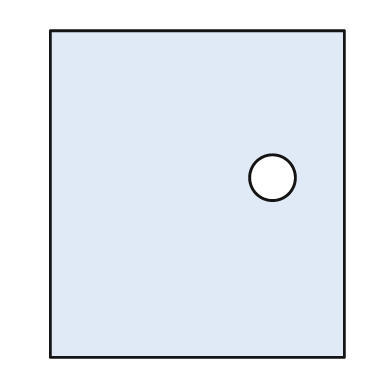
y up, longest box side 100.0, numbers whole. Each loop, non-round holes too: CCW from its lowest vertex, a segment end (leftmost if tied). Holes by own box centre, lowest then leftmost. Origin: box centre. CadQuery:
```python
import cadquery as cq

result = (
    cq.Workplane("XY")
    .moveTo(-45.0, -50.0)
    .lineTo(45.0, -50.0)
    .lineTo(45.0, 50.0)
    .lineTo(-45.0, 50.0)
    .close()
    .moveTo(23.0, 5.0)
    .circle(7.0)
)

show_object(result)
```